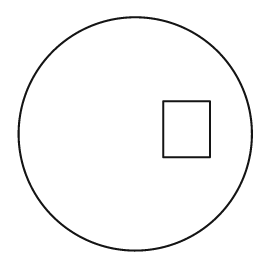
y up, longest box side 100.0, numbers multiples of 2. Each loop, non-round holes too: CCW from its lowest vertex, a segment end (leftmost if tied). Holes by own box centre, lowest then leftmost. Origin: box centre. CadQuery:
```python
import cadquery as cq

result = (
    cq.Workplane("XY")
    .moveTo(0.0, 0.0)
    .circle(50.0)
    .moveTo(12.0, -10.0)
    .lineTo(32.0, -10.0)
    .lineTo(32.0, 14.0)
    .lineTo(12.0, 14.0)
    .close()
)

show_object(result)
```